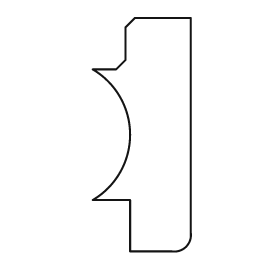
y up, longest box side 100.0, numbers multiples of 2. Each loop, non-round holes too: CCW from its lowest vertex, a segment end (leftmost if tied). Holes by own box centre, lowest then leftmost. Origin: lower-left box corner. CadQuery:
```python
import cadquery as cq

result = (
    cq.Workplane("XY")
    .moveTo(16.0, 0.0)
    .lineTo(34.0, 0.0)
    .threePointArc((40.0, 2.0), (42.0, 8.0))
    .lineTo(42.0, 100.0)
    .lineTo(18.0, 100.0)
    .lineTo(14.0, 96.0)
    .lineTo(14.0, 82.0)
    .lineTo(10.0, 78.0)
    .lineTo(0.0, 78.0)
    .threePointArc((16.0, 50.0), (0.0, 22.0))
    .lineTo(16.0, 22.0)
    .close()
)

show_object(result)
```